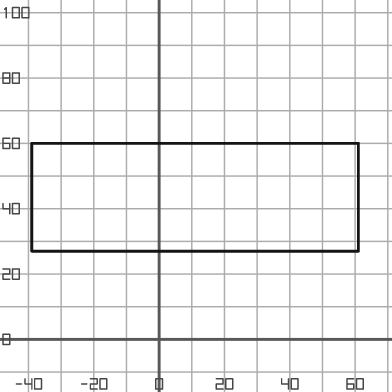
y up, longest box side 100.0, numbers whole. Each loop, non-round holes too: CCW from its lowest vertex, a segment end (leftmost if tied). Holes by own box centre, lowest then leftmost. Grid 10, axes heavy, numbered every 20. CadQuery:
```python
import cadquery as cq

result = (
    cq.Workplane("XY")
    .moveTo(-39.0, 27.0)
    .lineTo(61.0, 27.0)
    .lineTo(61.0, 60.0)
    .lineTo(-39.0, 60.0)
    .close()
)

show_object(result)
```